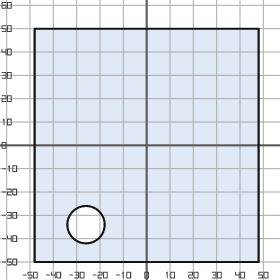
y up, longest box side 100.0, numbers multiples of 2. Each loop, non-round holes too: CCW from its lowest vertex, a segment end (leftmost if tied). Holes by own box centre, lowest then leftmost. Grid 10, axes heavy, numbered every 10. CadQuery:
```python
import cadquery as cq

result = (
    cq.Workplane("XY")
    .moveTo(-48.0, -50.0)
    .lineTo(48.0, -50.0)
    .lineTo(48.0, 50.0)
    .lineTo(-48.0, 50.0)
    .close()
    .moveTo(-26.0, -34.0)
    .circle(8.0)
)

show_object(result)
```